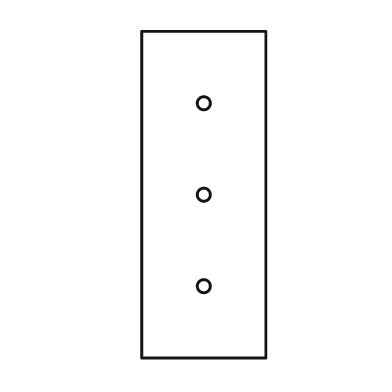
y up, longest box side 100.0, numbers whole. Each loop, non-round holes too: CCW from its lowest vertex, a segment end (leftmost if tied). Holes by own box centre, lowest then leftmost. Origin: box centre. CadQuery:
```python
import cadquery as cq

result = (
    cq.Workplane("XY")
    .moveTo(-19.0, -50.0)
    .lineTo(19.0, -50.0)
    .lineTo(19.0, 50.0)
    .lineTo(-19.0, 50.0)
    .close()
    .moveTo(0.0, -28.0)
    .circle(2.0)
    .moveTo(0.0, 0.0)
    .circle(2.0)
    .moveTo(0.0, 28.0)
    .circle(2.0)
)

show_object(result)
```